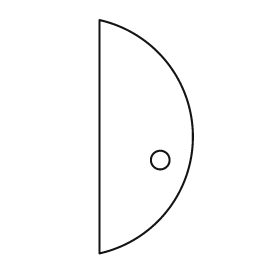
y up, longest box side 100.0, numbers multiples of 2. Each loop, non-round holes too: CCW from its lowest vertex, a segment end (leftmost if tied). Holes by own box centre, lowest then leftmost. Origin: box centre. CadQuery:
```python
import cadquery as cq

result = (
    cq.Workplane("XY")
    .moveTo(-20.0, -50.0)
    .threePointArc((20.0, 0.0), (-20.0, 50.0))
    .close()
    .moveTo(6.0, -10.0)
    .circle(4.0)
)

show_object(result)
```